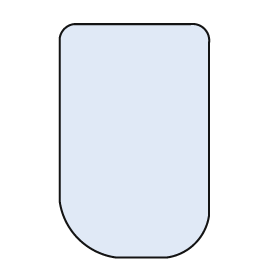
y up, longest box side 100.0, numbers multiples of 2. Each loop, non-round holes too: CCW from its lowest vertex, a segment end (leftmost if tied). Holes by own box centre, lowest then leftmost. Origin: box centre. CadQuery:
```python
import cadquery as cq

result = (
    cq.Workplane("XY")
    .moveTo(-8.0, -50.0)
    .lineTo(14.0, -50.0)
    .threePointArc((26.0, -44.0), (32.0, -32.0))
    .lineTo(32.0, 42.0)
    .threePointArc((30.0, 48.0), (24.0, 50.0))
    .lineTo(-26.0, 50.0)
    .threePointArc((-30.0, 48.0), (-32.0, 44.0))
    .lineTo(-32.0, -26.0)
    .threePointArc((-24.0, -42.0), (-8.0, -50.0))
    .close()
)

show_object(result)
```